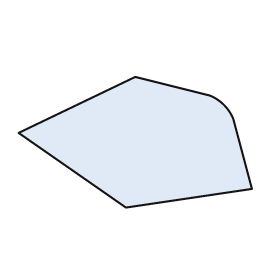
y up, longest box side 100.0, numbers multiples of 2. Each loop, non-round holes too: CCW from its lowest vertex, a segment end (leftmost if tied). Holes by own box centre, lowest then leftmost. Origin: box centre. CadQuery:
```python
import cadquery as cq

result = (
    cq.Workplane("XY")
    .moveTo(-4.0, -28.0)
    .lineTo(50.0, -20.0)
    .lineTo(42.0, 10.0)
    .threePointArc((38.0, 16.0), (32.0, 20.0))
    .lineTo(0.0, 28.0)
    .lineTo(-50.0, 4.0)
    .close()
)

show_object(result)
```